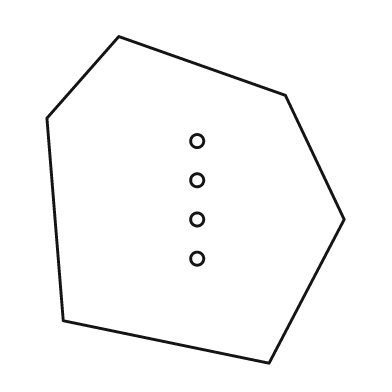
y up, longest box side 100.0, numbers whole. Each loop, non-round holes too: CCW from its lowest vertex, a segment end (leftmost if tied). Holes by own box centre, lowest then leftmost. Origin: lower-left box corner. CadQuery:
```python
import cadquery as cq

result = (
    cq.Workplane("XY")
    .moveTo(68.0, 0.0)
    .lineTo(91.0, 44.0)
    .lineTo(73.0, 82.0)
    .lineTo(22.0, 100.0)
    .lineTo(0.0, 75.0)
    .lineTo(5.0, 13.0)
    .close()
    .moveTo(46.0, 32.0)
    .circle(2.0)
    .moveTo(46.0, 44.0)
    .circle(2.0)
    .moveTo(46.0, 56.0)
    .circle(2.0)
    .moveTo(46.0, 68.0)
    .circle(2.0)
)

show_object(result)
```